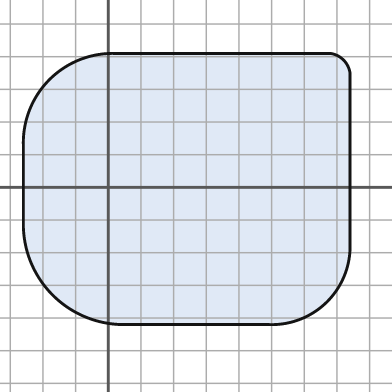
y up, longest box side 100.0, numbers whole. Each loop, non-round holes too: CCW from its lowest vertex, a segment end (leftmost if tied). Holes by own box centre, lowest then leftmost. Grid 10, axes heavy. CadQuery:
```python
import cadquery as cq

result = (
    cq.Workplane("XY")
    .moveTo(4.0, -42.0)
    .lineTo(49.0, -42.0)
    .threePointArc((67.0, -35.0), (74.0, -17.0))
    .lineTo(74.0, 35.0)
    .threePointArc((72.0, 39.0), (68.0, 41.0))
    .lineTo(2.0, 41.0)
    .threePointArc((-18.0, 33.0), (-26.0, 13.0))
    .lineTo(-26.0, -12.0)
    .threePointArc((-17.0, -33.0), (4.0, -42.0))
    .close()
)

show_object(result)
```